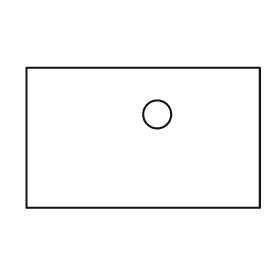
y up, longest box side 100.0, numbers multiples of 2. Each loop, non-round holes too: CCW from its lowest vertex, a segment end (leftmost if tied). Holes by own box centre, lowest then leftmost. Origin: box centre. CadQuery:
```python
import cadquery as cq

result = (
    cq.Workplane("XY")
    .moveTo(-50.0, -30.0)
    .lineTo(50.0, -30.0)
    .lineTo(50.0, 30.0)
    .lineTo(-50.0, 30.0)
    .close()
    .moveTo(6.0, 10.0)
    .circle(6.0)
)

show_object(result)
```